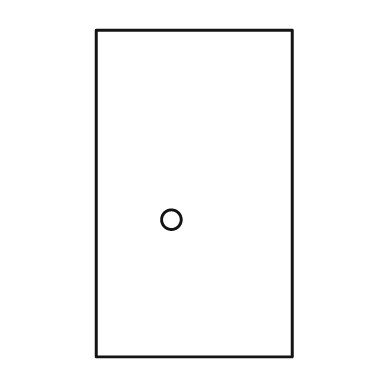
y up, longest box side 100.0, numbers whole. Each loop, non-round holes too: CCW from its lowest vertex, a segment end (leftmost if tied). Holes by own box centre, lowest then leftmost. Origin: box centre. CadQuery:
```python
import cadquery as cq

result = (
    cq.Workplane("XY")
    .moveTo(-30.0, -50.0)
    .lineTo(30.0, -50.0)
    .lineTo(30.0, 50.0)
    .lineTo(-30.0, 50.0)
    .close()
    .moveTo(-7.0, -8.0)
    .circle(3.0)
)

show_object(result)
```